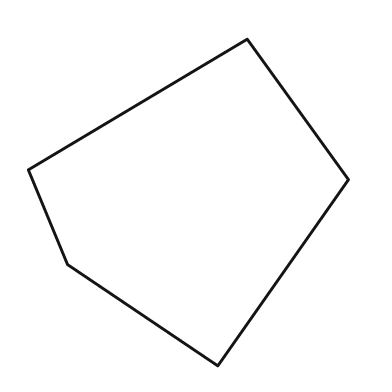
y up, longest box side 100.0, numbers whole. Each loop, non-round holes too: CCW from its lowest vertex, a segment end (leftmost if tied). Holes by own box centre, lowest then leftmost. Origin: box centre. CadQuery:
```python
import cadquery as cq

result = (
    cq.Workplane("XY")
    .moveTo(9.0, -50.0)
    .lineTo(49.0, 7.0)
    .lineTo(18.0, 50.0)
    .lineTo(-49.0, 10.0)
    .lineTo(-37.0, -19.0)
    .close()
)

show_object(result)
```